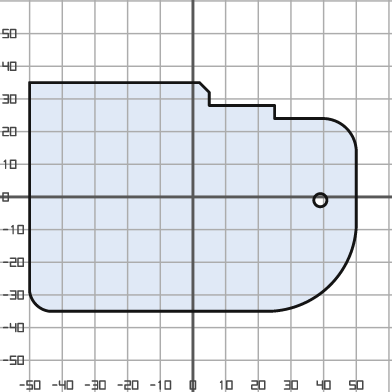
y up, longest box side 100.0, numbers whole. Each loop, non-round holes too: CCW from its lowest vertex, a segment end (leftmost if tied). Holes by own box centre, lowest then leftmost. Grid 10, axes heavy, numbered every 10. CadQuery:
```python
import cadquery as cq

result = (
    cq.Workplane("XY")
    .moveTo(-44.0, -35.0)
    .lineTo(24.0, -35.0)
    .threePointArc((42.0, -27.0), (50.0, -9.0))
    .lineTo(50.0, 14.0)
    .threePointArc((47.0, 21.0), (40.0, 24.0))
    .lineTo(25.0, 24.0)
    .lineTo(25.0, 28.0)
    .lineTo(5.0, 28.0)
    .lineTo(5.0, 32.0)
    .lineTo(2.0, 35.0)
    .lineTo(-50.0, 35.0)
    .lineTo(-50.0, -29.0)
    .threePointArc((-48.0, -33.0), (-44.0, -35.0))
    .close()
    .moveTo(39.0, -1.0)
    .circle(2.0)
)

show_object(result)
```